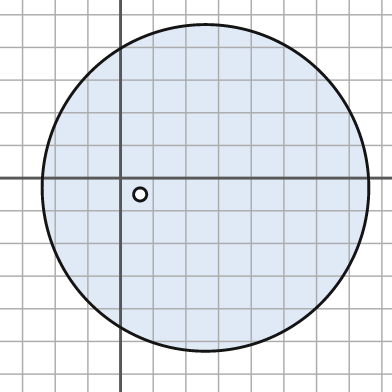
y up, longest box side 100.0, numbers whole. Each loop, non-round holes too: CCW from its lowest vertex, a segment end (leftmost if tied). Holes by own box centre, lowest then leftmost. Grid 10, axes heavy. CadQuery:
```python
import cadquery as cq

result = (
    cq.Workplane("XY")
    .moveTo(26.0, -3.0)
    .circle(50.0)
    .moveTo(6.0, -5.0)
    .circle(2.0)
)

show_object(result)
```